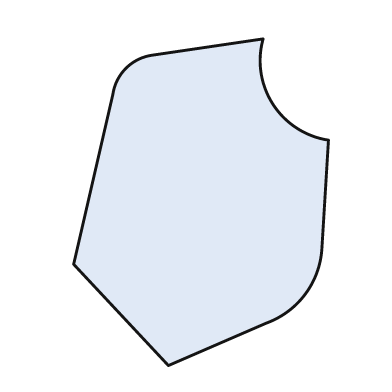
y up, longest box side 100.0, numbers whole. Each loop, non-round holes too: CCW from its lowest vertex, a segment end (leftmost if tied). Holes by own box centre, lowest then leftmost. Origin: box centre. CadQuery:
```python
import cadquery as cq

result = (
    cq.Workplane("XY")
    .moveTo(-10.0, -50.0)
    .lineTo(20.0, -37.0)
    .threePointArc((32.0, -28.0), (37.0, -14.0))
    .lineTo(39.0, 19.0)
    .threePointArc((22.0, 30.0), (19.0, 50.0))
    .lineTo(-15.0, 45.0)
    .threePointArc((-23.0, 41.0), (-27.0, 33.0))
    .lineTo(-39.0, -19.0)
    .close()
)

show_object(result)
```